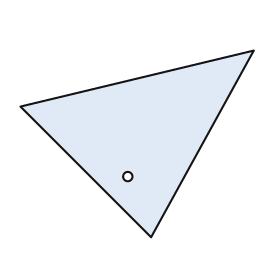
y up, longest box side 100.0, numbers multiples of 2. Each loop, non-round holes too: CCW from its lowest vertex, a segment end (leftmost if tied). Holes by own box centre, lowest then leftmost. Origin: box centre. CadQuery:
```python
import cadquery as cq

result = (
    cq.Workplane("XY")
    .moveTo(6.0, -40.0)
    .lineTo(50.0, 40.0)
    .lineTo(-50.0, 16.0)
    .close()
    .moveTo(-4.0, -14.0)
    .circle(2.0)
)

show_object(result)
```